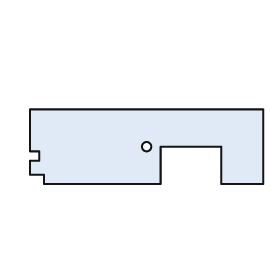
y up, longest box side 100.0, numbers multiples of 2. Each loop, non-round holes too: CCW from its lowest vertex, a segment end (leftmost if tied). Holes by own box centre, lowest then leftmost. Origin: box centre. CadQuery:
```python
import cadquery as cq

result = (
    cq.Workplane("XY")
    .moveTo(-44.0, -16.0)
    .lineTo(6.0, -16.0)
    .lineTo(6.0, 0.0)
    .lineTo(32.0, 0.0)
    .lineTo(32.0, -16.0)
    .lineTo(50.0, -16.0)
    .lineTo(50.0, 16.0)
    .lineTo(-50.0, 16.0)
    .lineTo(-50.0, -2.0)
    .lineTo(-46.0, -2.0)
    .lineTo(-46.0, -6.0)
    .lineTo(-50.0, -6.0)
    .lineTo(-50.0, -12.0)
    .lineTo(-44.0, -12.0)
    .close()
    .moveTo(0.0, 0.0)
    .circle(2.0)
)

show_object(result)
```